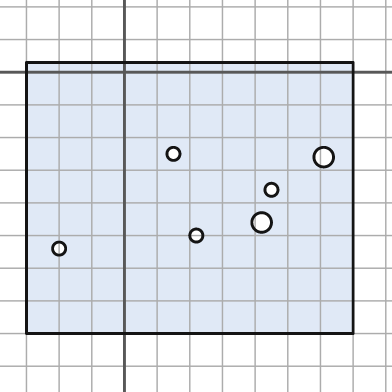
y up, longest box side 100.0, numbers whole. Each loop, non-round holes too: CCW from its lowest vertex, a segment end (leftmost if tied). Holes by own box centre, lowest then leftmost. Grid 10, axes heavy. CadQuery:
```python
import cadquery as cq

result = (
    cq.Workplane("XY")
    .moveTo(-30.0, -80.0)
    .lineTo(70.0, -80.0)
    .lineTo(70.0, 3.0)
    .lineTo(-30.0, 3.0)
    .close()
    .moveTo(-20.0, -54.0)
    .circle(2.0)
    .moveTo(22.0, -50.0)
    .circle(2.0)
    .moveTo(42.0, -46.0)
    .circle(3.0)
    .moveTo(45.0, -36.0)
    .circle(2.0)
    .moveTo(61.0, -26.0)
    .circle(3.0)
    .moveTo(15.0, -25.0)
    .circle(2.0)
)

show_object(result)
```